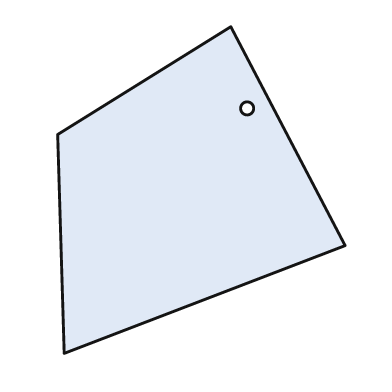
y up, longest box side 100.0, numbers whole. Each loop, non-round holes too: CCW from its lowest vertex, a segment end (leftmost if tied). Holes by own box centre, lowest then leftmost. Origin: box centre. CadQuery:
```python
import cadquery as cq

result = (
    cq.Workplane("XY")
    .moveTo(-42.0, -50.0)
    .lineTo(44.0, -17.0)
    .lineTo(9.0, 50.0)
    .lineTo(-44.0, 17.0)
    .close()
    .moveTo(14.0, 25.0)
    .circle(2.0)
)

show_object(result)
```